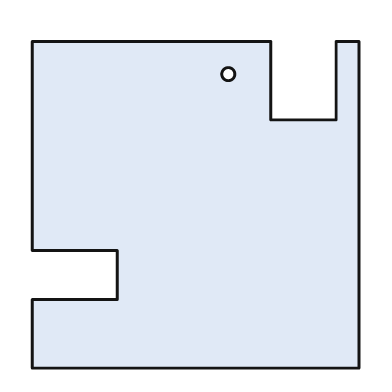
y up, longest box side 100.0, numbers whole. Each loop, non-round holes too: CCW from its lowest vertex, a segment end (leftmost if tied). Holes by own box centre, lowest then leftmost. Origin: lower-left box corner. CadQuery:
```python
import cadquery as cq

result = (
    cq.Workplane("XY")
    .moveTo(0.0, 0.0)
    .lineTo(100.0, 0.0)
    .lineTo(100.0, 100.0)
    .lineTo(93.0, 100.0)
    .lineTo(93.0, 76.0)
    .lineTo(73.0, 76.0)
    .lineTo(73.0, 100.0)
    .lineTo(0.0, 100.0)
    .lineTo(0.0, 36.0)
    .lineTo(26.0, 36.0)
    .lineTo(26.0, 21.0)
    .lineTo(0.0, 21.0)
    .close()
    .moveTo(60.0, 90.0)
    .circle(2.0)
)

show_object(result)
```